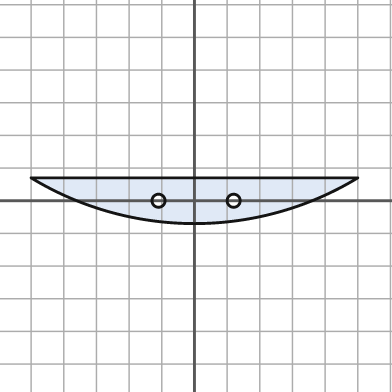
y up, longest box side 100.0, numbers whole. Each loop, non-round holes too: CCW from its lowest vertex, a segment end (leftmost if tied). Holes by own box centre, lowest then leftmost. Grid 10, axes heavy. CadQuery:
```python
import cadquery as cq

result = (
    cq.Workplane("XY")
    .moveTo(-50.0, 7.0)
    .threePointArc((0.0, -7.0), (50.0, 7.0))
    .close()
    .moveTo(-11.0, 0.0)
    .circle(2.0)
    .moveTo(12.0, 0.0)
    .circle(2.0)
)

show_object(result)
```